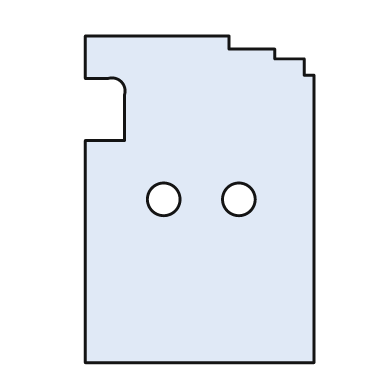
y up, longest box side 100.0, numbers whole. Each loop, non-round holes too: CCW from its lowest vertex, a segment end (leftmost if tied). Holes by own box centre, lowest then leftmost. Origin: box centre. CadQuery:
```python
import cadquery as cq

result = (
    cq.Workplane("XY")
    .moveTo(-35.0, -50.0)
    .lineTo(35.0, -50.0)
    .lineTo(35.0, 38.0)
    .lineTo(32.0, 38.0)
    .lineTo(32.0, 43.0)
    .lineTo(23.0, 43.0)
    .lineTo(23.0, 46.0)
    .lineTo(9.0, 46.0)
    .lineTo(9.0, 50.0)
    .lineTo(-35.0, 50.0)
    .lineTo(-35.0, 37.0)
    .lineTo(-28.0, 37.0)
    .threePointArc((-24.0, 36.0), (-23.0, 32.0))
    .lineTo(-23.0, 18.0)
    .lineTo(-35.0, 18.0)
    .close()
    .moveTo(-11.0, 0.0)
    .circle(5.0)
    .moveTo(12.0, 0.0)
    .circle(5.0)
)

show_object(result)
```